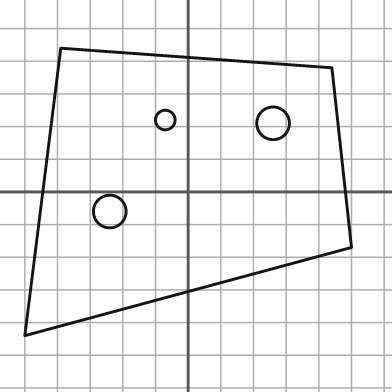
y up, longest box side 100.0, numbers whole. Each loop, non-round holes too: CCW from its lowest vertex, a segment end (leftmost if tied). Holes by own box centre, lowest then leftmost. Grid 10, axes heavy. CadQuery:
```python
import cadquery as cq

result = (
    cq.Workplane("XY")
    .moveTo(-50.0, -44.0)
    .lineTo(50.0, -17.0)
    .lineTo(44.0, 38.0)
    .lineTo(-39.0, 44.0)
    .close()
    .moveTo(-24.0, -6.0)
    .circle(5.0)
    .moveTo(26.0, 21.0)
    .circle(5.0)
    .moveTo(-7.0, 22.0)
    .circle(3.0)
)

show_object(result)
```